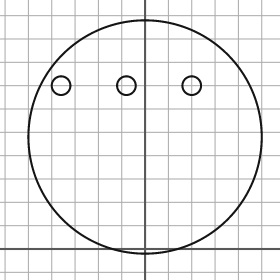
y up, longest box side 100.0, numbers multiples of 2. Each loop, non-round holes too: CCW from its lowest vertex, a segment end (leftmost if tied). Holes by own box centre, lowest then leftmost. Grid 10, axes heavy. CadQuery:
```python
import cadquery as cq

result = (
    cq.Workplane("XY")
    .moveTo(0.0, 48.0)
    .circle(50.0)
    .moveTo(-36.0, 70.0)
    .circle(4.0)
    .moveTo(-8.0, 70.0)
    .circle(4.0)
    .moveTo(20.0, 70.0)
    .circle(4.0)
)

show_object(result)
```